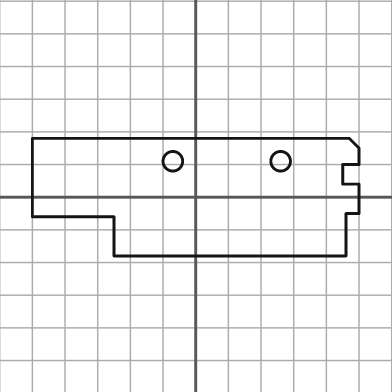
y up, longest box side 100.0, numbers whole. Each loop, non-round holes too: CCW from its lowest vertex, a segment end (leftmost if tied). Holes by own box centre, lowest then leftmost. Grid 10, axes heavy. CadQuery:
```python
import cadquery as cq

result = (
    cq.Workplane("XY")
    .moveTo(-25.0, -18.0)
    .lineTo(46.0, -18.0)
    .lineTo(46.0, -5.0)
    .lineTo(50.0, -5.0)
    .lineTo(50.0, 4.0)
    .lineTo(45.0, 4.0)
    .lineTo(45.0, 10.0)
    .lineTo(50.0, 10.0)
    .lineTo(50.0, 15.0)
    .lineTo(47.0, 18.0)
    .lineTo(-50.0, 18.0)
    .lineTo(-50.0, -6.0)
    .lineTo(-25.0, -6.0)
    .close()
    .moveTo(-7.0, 11.0)
    .circle(3.0)
    .moveTo(26.0, 11.0)
    .circle(3.0)
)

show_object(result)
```